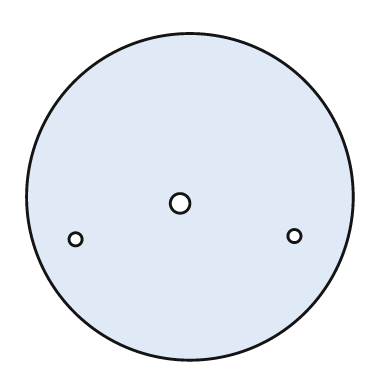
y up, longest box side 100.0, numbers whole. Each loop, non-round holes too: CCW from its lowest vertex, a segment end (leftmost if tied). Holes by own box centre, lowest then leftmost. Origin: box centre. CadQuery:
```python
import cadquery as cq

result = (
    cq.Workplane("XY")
    .moveTo(0.0, 0.0)
    .circle(50.0)
    .moveTo(-35.0, -13.0)
    .circle(2.0)
    .moveTo(32.0, -12.0)
    .circle(2.0)
    .moveTo(-3.0, -2.0)
    .circle(3.0)
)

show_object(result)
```